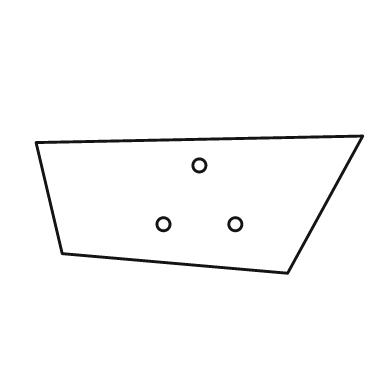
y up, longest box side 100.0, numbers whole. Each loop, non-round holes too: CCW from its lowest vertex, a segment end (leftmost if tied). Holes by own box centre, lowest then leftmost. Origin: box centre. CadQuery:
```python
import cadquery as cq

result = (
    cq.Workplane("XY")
    .moveTo(27.0, -21.0)
    .lineTo(50.0, 21.0)
    .lineTo(-50.0, 19.0)
    .lineTo(-42.0, -15.0)
    .close()
    .moveTo(-11.0, -6.0)
    .circle(2.0)
    .moveTo(11.0, -6.0)
    .circle(2.0)
    .moveTo(0.0, 12.0)
    .circle(2.0)
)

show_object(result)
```